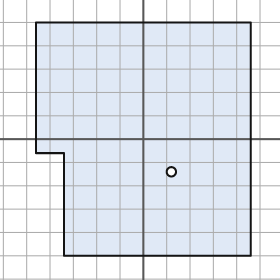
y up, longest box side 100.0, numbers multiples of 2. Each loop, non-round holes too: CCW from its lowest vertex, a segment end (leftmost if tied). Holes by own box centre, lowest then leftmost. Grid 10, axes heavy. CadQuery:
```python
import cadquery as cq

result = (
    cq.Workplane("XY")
    .moveTo(-34.0, -50.0)
    .lineTo(46.0, -50.0)
    .lineTo(46.0, 50.0)
    .lineTo(-46.0, 50.0)
    .lineTo(-46.0, -6.0)
    .lineTo(-34.0, -6.0)
    .close()
    .moveTo(12.0, -14.0)
    .circle(2.0)
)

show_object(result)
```